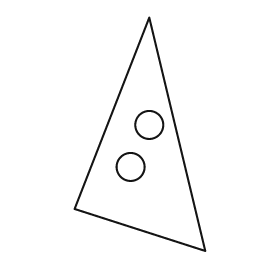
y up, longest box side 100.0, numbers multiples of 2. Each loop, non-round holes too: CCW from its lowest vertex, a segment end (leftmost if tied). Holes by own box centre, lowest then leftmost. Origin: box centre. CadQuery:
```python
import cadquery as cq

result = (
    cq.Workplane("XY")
    .moveTo(28.0, -50.0)
    .lineTo(4.0, 50.0)
    .lineTo(-28.0, -32.0)
    .close()
    .moveTo(-4.0, -14.0)
    .circle(6.0)
    .moveTo(4.0, 4.0)
    .circle(6.0)
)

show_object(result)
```